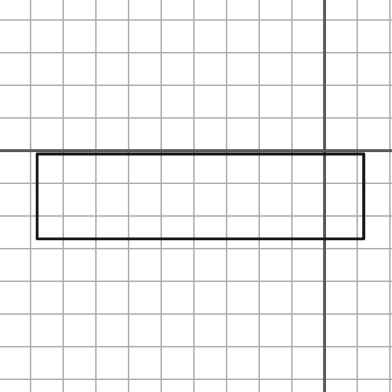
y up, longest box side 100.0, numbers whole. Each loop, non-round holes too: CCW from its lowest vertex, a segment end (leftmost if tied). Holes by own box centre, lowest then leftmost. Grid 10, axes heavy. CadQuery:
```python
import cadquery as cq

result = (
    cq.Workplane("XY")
    .moveTo(-88.0, -27.0)
    .lineTo(12.0, -27.0)
    .lineTo(12.0, -1.0)
    .lineTo(-88.0, -1.0)
    .close()
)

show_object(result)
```